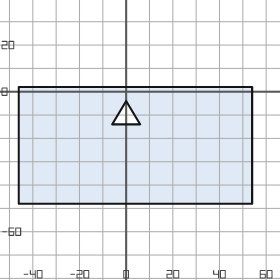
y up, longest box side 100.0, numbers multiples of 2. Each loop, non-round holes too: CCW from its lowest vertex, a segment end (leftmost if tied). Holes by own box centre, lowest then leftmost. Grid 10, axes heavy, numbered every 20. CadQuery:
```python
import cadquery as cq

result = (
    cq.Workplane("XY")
    .moveTo(-46.0, -48.0)
    .lineTo(54.0, -48.0)
    .lineTo(54.0, 2.0)
    .lineTo(-46.0, 2.0)
    .close()
    .moveTo(-6.0, -14.0)
    .lineTo(6.0, -14.0)
    .lineTo(0.0, -4.0)
    .close()
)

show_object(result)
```